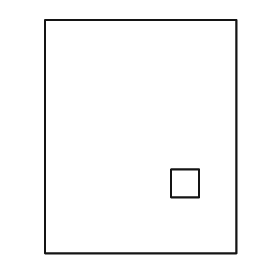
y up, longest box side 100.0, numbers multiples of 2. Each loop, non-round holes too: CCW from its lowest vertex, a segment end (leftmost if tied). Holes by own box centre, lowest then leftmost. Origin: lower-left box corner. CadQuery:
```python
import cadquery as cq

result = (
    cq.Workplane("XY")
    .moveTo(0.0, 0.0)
    .lineTo(82.0, 0.0)
    .lineTo(82.0, 100.0)
    .lineTo(0.0, 100.0)
    .close()
    .moveTo(54.0, 24.0)
    .lineTo(66.0, 24.0)
    .lineTo(66.0, 36.0)
    .lineTo(54.0, 36.0)
    .close()
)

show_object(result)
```